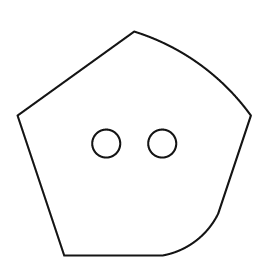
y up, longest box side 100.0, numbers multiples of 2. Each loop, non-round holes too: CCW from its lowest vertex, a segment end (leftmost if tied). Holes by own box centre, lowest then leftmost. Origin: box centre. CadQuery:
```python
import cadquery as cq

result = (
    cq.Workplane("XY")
    .moveTo(-30.0, -48.0)
    .lineTo(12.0, -48.0)
    .threePointArc((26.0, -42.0), (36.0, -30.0))
    .lineTo(50.0, 12.0)
    .threePointArc((28.0, 34.0), (0.0, 48.0))
    .lineTo(-50.0, 12.0)
    .close()
    .moveTo(-12.0, 0.0)
    .circle(6.0)
    .moveTo(12.0, 0.0)
    .circle(6.0)
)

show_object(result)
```